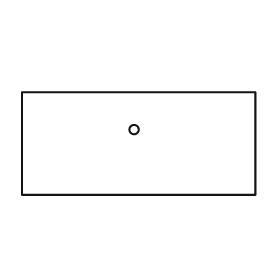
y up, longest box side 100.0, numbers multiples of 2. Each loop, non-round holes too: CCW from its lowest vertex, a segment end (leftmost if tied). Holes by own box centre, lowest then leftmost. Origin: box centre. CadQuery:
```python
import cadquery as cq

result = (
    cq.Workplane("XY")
    .moveTo(-50.0, -22.0)
    .lineTo(50.0, -22.0)
    .lineTo(50.0, 22.0)
    .lineTo(-50.0, 22.0)
    .close()
    .moveTo(-2.0, 6.0)
    .circle(2.0)
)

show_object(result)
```